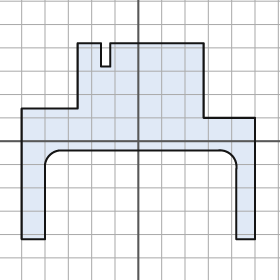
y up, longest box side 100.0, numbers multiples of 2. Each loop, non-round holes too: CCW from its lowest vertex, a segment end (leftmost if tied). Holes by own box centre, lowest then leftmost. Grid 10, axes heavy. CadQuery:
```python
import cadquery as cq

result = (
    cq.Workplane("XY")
    .moveTo(-50.0, -42.0)
    .lineTo(-40.0, -42.0)
    .lineTo(-40.0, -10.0)
    .threePointArc((-38.0, -6.0), (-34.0, -4.0))
    .lineTo(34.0, -4.0)
    .threePointArc((40.0, -6.0), (42.0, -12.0))
    .lineTo(42.0, -42.0)
    .lineTo(50.0, -42.0)
    .lineTo(50.0, 10.0)
    .lineTo(28.0, 10.0)
    .lineTo(28.0, 42.0)
    .lineTo(-12.0, 42.0)
    .lineTo(-12.0, 32.0)
    .lineTo(-16.0, 32.0)
    .lineTo(-16.0, 42.0)
    .lineTo(-26.0, 42.0)
    .lineTo(-26.0, 14.0)
    .lineTo(-50.0, 14.0)
    .close()
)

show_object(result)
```